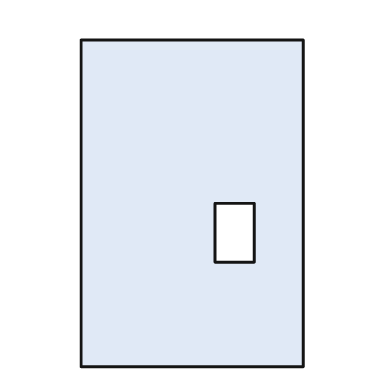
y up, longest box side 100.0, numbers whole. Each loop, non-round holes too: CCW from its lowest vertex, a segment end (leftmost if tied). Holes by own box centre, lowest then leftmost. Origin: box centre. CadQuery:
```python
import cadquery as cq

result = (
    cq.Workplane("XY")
    .moveTo(-34.0, -50.0)
    .lineTo(34.0, -50.0)
    .lineTo(34.0, 50.0)
    .lineTo(-34.0, 50.0)
    .close()
    .moveTo(7.0, -18.0)
    .lineTo(19.0, -18.0)
    .lineTo(19.0, 0.0)
    .lineTo(7.0, 0.0)
    .close()
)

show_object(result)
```